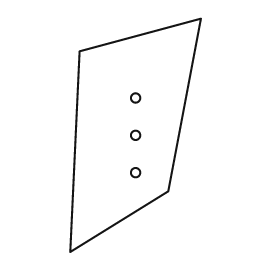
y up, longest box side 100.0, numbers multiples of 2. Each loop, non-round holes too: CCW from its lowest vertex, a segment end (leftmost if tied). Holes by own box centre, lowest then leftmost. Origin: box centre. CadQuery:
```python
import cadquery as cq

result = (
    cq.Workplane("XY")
    .moveTo(-28.0, -50.0)
    .lineTo(14.0, -24.0)
    .lineTo(28.0, 50.0)
    .lineTo(-24.0, 36.0)
    .close()
    .moveTo(0.0, -16.0)
    .circle(2.0)
    .moveTo(0.0, 0.0)
    .circle(2.0)
    .moveTo(0.0, 16.0)
    .circle(2.0)
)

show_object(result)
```